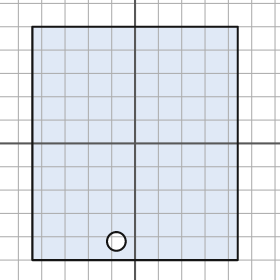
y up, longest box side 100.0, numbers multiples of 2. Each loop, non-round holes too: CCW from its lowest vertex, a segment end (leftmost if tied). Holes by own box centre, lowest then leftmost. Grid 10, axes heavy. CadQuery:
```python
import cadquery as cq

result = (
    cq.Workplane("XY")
    .moveTo(-44.0, -50.0)
    .lineTo(44.0, -50.0)
    .lineTo(44.0, 50.0)
    .lineTo(-44.0, 50.0)
    .close()
    .moveTo(-8.0, -42.0)
    .circle(4.0)
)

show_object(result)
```